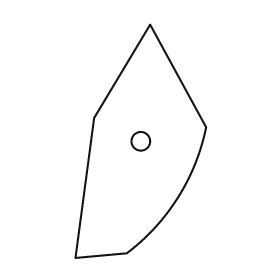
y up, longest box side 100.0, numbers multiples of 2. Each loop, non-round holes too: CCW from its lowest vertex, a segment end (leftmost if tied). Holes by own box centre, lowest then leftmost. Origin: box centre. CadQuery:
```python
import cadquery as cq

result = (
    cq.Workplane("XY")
    .moveTo(-28.0, -50.0)
    .lineTo(-6.0, -48.0)
    .threePointArc((16.0, -24.0), (28.0, 6.0))
    .lineTo(4.0, 50.0)
    .lineTo(-20.0, 10.0)
    .close()
    .moveTo(0.0, 0.0)
    .circle(4.0)
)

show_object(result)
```